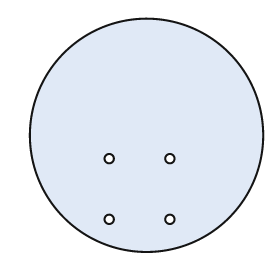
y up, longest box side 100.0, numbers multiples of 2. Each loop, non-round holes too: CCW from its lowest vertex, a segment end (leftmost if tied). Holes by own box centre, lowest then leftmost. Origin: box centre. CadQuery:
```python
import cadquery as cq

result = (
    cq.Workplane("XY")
    .moveTo(0.0, 0.0)
    .circle(50.0)
    .moveTo(-16.0, -36.0)
    .circle(2.0)
    .moveTo(10.0, -36.0)
    .circle(2.0)
    .moveTo(-16.0, -10.0)
    .circle(2.0)
    .moveTo(10.0, -10.0)
    .circle(2.0)
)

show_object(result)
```